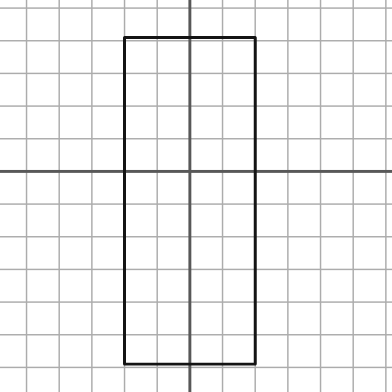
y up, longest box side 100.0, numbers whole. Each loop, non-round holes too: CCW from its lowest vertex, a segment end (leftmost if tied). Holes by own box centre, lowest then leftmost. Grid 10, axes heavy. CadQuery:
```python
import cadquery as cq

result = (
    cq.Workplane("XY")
    .moveTo(-20.0, -59.0)
    .lineTo(20.0, -59.0)
    .lineTo(20.0, 41.0)
    .lineTo(-20.0, 41.0)
    .close()
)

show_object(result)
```